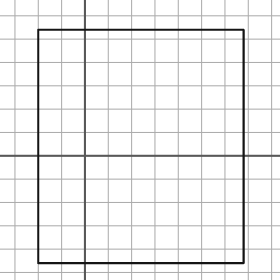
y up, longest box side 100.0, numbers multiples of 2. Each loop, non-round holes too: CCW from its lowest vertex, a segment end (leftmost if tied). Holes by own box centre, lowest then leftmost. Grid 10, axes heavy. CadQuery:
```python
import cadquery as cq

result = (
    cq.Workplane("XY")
    .moveTo(-20.0, -46.0)
    .lineTo(68.0, -46.0)
    .lineTo(68.0, 54.0)
    .lineTo(-20.0, 54.0)
    .close()
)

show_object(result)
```